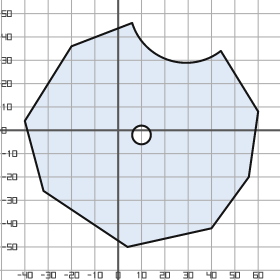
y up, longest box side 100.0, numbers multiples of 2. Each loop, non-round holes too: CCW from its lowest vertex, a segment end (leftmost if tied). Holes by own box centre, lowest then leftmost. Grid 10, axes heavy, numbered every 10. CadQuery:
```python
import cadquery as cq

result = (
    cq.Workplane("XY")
    .moveTo(4.0, -50.0)
    .lineTo(40.0, -42.0)
    .lineTo(56.0, -20.0)
    .lineTo(60.0, 8.0)
    .lineTo(44.0, 34.0)
    .threePointArc((22.0, 30.0), (6.0, 46.0))
    .lineTo(-20.0, 36.0)
    .lineTo(-40.0, 4.0)
    .lineTo(-32.0, -26.0)
    .close()
    .moveTo(10.0, -2.0)
    .circle(4.0)
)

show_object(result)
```